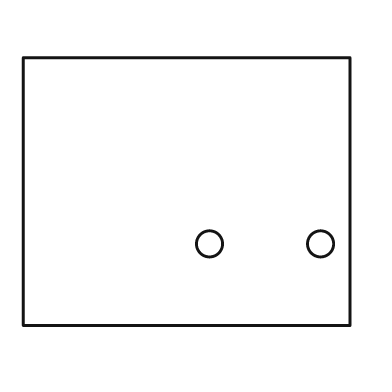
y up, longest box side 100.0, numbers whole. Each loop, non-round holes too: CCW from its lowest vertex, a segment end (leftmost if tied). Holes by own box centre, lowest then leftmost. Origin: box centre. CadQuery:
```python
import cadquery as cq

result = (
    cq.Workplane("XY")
    .moveTo(-50.0, -41.0)
    .lineTo(50.0, -41.0)
    .lineTo(50.0, 41.0)
    .lineTo(-50.0, 41.0)
    .close()
    .moveTo(7.0, -16.0)
    .circle(4.0)
    .moveTo(41.0, -16.0)
    .circle(4.0)
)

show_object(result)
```